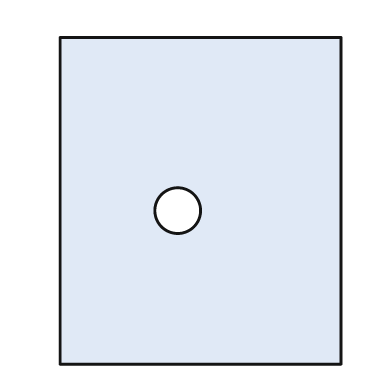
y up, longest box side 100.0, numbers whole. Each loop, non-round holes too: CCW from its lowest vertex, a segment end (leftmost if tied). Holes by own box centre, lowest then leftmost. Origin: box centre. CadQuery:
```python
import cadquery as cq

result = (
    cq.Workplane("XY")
    .moveTo(-43.0, -50.0)
    .lineTo(43.0, -50.0)
    .lineTo(43.0, 50.0)
    .lineTo(-43.0, 50.0)
    .close()
    .moveTo(-7.0, -3.0)
    .circle(7.0)
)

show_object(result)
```